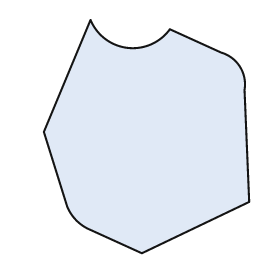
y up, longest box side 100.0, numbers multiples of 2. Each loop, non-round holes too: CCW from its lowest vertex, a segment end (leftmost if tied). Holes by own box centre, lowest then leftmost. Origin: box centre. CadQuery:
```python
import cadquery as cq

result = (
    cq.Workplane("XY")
    .moveTo(-2.0, -50.0)
    .lineTo(44.0, -28.0)
    .lineTo(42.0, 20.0)
    .threePointArc((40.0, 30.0), (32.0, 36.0))
    .lineTo(10.0, 46.0)
    .threePointArc((-8.0, 38.0), (-24.0, 50.0))
    .lineTo(-44.0, 2.0)
    .lineTo(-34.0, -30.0)
    .threePointArc((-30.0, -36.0), (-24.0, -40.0))
    .close()
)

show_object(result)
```